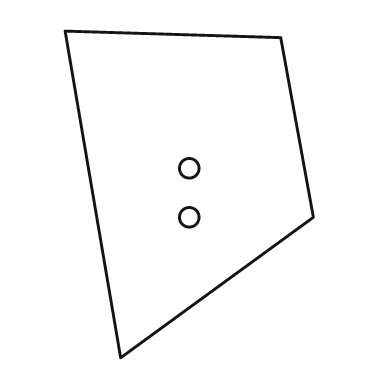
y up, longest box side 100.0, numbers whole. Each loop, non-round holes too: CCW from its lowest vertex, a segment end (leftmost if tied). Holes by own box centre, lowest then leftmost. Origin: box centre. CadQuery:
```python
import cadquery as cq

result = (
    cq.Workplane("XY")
    .moveTo(-21.0, -50.0)
    .lineTo(38.0, -7.0)
    .lineTo(28.0, 48.0)
    .lineTo(-38.0, 50.0)
    .close()
    .moveTo(0.0, -7.0)
    .circle(3.0)
    .moveTo(0.0, 8.0)
    .circle(3.0)
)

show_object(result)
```